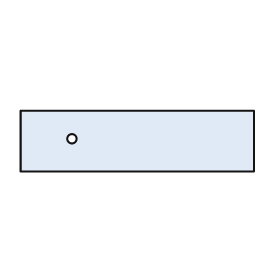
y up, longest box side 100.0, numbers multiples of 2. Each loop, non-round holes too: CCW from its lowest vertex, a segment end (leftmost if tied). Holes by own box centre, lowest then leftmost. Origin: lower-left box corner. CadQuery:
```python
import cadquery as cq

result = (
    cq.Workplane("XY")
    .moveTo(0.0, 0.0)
    .lineTo(100.0, 0.0)
    .lineTo(100.0, 26.0)
    .lineTo(0.0, 26.0)
    .close()
    .moveTo(22.0, 14.0)
    .circle(2.0)
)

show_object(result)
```